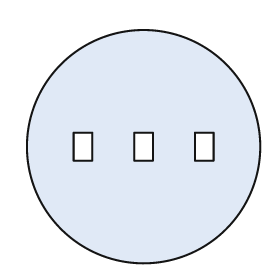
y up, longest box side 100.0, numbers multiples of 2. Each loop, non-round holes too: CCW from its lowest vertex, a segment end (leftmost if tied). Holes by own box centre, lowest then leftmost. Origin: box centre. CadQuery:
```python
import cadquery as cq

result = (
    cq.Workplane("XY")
    .moveTo(0.0, 0.0)
    .circle(50.0)
    .moveTo(-30.0, -6.0)
    .lineTo(-22.0, -6.0)
    .lineTo(-22.0, 6.0)
    .lineTo(-30.0, 6.0)
    .close()
    .moveTo(-4.0, -6.0)
    .lineTo(4.0, -6.0)
    .lineTo(4.0, 6.0)
    .lineTo(-4.0, 6.0)
    .close()
    .moveTo(22.0, -6.0)
    .lineTo(30.0, -6.0)
    .lineTo(30.0, 6.0)
    .lineTo(22.0, 6.0)
    .close()
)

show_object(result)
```